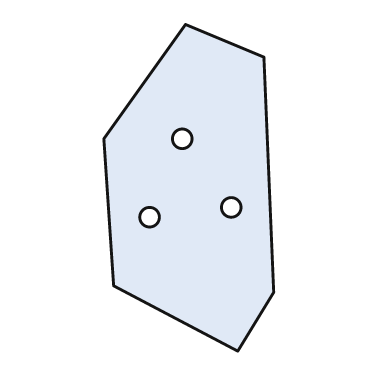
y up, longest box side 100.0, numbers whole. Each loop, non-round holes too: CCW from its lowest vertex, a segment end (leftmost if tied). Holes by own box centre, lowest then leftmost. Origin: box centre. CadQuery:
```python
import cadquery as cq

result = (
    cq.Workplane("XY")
    .moveTo(15.0, -50.0)
    .lineTo(26.0, -32.0)
    .lineTo(23.0, 40.0)
    .lineTo(-1.0, 50.0)
    .lineTo(-26.0, 15.0)
    .lineTo(-23.0, -30.0)
    .close()
    .moveTo(-12.0, -9.0)
    .circle(3.0)
    .moveTo(13.0, -6.0)
    .circle(3.0)
    .moveTo(-2.0, 15.0)
    .circle(3.0)
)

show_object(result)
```